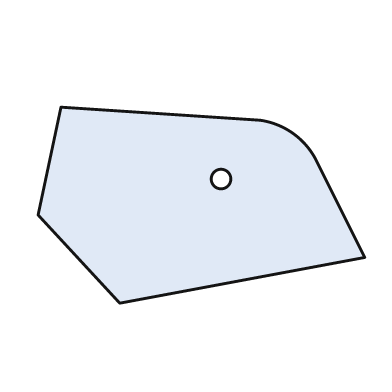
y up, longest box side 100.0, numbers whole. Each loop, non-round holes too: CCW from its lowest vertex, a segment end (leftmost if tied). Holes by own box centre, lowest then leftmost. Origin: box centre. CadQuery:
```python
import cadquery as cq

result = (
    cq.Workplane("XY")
    .moveTo(-25.0, -30.0)
    .lineTo(50.0, -16.0)
    .lineTo(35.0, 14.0)
    .threePointArc((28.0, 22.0), (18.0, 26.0))
    .lineTo(-43.0, 30.0)
    .lineTo(-50.0, -3.0)
    .close()
    .moveTo(6.0, 8.0)
    .circle(3.0)
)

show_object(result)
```